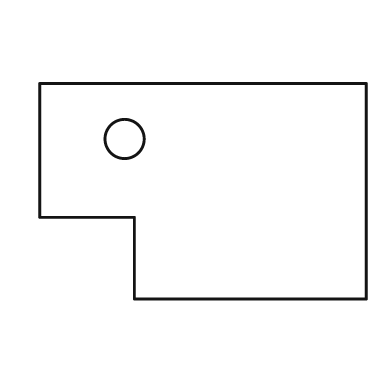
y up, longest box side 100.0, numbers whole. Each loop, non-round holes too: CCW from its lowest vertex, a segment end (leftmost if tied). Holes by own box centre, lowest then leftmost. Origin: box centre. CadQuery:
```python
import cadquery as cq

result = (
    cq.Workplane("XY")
    .moveTo(-21.0, -33.0)
    .lineTo(50.0, -33.0)
    .lineTo(50.0, 33.0)
    .lineTo(-50.0, 33.0)
    .lineTo(-50.0, -8.0)
    .lineTo(-21.0, -8.0)
    .close()
    .moveTo(-24.0, 16.0)
    .circle(6.0)
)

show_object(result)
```